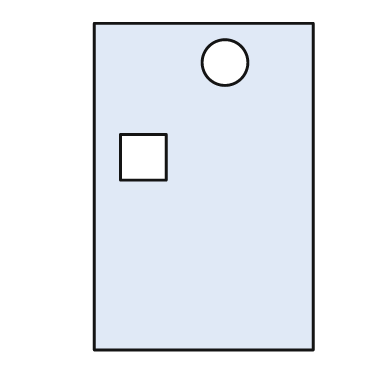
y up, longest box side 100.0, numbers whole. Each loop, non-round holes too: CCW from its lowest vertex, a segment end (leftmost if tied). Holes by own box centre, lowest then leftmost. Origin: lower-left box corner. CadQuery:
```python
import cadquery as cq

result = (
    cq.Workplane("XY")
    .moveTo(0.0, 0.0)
    .lineTo(67.0, 0.0)
    .lineTo(67.0, 100.0)
    .lineTo(0.0, 100.0)
    .close()
    .moveTo(8.0, 52.0)
    .lineTo(22.0, 52.0)
    .lineTo(22.0, 66.0)
    .lineTo(8.0, 66.0)
    .close()
    .moveTo(40.0, 88.0)
    .circle(7.0)
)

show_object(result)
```